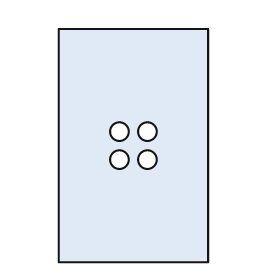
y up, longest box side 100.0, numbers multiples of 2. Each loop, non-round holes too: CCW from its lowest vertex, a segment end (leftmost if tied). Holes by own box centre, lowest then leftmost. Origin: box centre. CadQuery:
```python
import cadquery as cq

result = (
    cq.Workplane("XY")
    .moveTo(-32.0, -50.0)
    .lineTo(32.0, -50.0)
    .lineTo(32.0, 50.0)
    .lineTo(-32.0, 50.0)
    .close()
    .moveTo(-6.0, -6.0)
    .circle(4.0)
    .moveTo(6.0, -6.0)
    .circle(4.0)
    .moveTo(-6.0, 6.0)
    .circle(4.0)
    .moveTo(6.0, 6.0)
    .circle(4.0)
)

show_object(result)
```